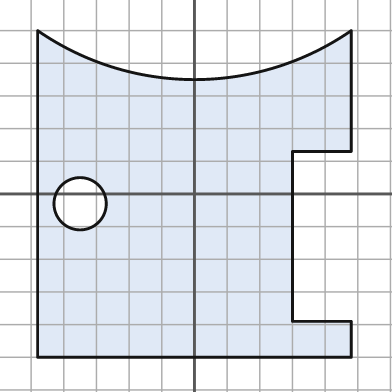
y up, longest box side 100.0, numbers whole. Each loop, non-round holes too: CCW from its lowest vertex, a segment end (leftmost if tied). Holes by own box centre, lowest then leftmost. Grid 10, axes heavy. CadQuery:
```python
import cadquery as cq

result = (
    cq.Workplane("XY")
    .moveTo(-48.0, -50.0)
    .lineTo(48.0, -50.0)
    .lineTo(48.0, -39.0)
    .lineTo(30.0, -39.0)
    .lineTo(30.0, 13.0)
    .lineTo(48.0, 13.0)
    .lineTo(48.0, 50.0)
    .threePointArc((0.0, 35.0), (-48.0, 50.0))
    .close()
    .moveTo(-35.0, -3.0)
    .circle(8.0)
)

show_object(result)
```